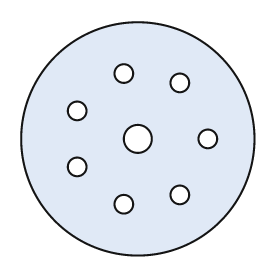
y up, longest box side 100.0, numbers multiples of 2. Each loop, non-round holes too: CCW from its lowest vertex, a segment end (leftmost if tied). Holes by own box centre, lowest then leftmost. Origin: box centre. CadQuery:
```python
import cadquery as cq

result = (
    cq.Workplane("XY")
    .moveTo(0.0, 0.0)
    .circle(50.0)
    .moveTo(-6.0, -28.0)
    .circle(4.0)
    .moveTo(18.0, -24.0)
    .circle(4.0)
    .moveTo(-26.0, -12.0)
    .circle(4.0)
    .moveTo(0.0, 0.0)
    .circle(6.0)
    .moveTo(30.0, 0.0)
    .circle(4.0)
    .moveTo(-26.0, 12.0)
    .circle(4.0)
    .moveTo(18.0, 24.0)
    .circle(4.0)
    .moveTo(-6.0, 28.0)
    .circle(4.0)
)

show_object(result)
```